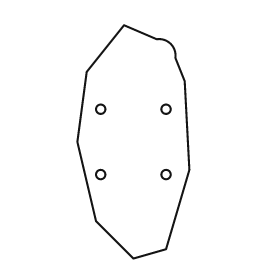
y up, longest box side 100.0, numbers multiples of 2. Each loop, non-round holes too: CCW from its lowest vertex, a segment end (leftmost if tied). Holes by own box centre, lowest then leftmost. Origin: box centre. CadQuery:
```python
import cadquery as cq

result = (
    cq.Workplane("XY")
    .moveTo(0.0, -50.0)
    .lineTo(14.0, -46.0)
    .lineTo(24.0, -12.0)
    .lineTo(22.0, 26.0)
    .lineTo(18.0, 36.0)
    .threePointArc((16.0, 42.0), (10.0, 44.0))
    .lineTo(-4.0, 50.0)
    .lineTo(-20.0, 30.0)
    .lineTo(-24.0, 0.0)
    .lineTo(-16.0, -34.0)
    .close()
    .moveTo(-14.0, -14.0)
    .circle(2.0)
    .moveTo(14.0, -14.0)
    .circle(2.0)
    .moveTo(-14.0, 14.0)
    .circle(2.0)
    .moveTo(14.0, 14.0)
    .circle(2.0)
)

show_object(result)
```